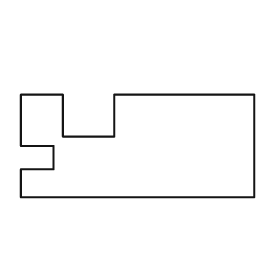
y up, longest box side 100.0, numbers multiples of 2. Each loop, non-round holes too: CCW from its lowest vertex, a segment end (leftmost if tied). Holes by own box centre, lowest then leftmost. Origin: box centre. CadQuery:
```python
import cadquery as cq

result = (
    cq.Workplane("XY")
    .moveTo(-50.0, -22.0)
    .lineTo(50.0, -22.0)
    .lineTo(50.0, 22.0)
    .lineTo(-10.0, 22.0)
    .lineTo(-10.0, 4.0)
    .lineTo(-32.0, 4.0)
    .lineTo(-32.0, 22.0)
    .lineTo(-50.0, 22.0)
    .lineTo(-50.0, 0.0)
    .lineTo(-36.0, 0.0)
    .lineTo(-36.0, -10.0)
    .lineTo(-50.0, -10.0)
    .close()
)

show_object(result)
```